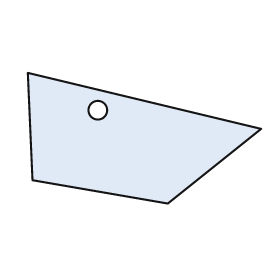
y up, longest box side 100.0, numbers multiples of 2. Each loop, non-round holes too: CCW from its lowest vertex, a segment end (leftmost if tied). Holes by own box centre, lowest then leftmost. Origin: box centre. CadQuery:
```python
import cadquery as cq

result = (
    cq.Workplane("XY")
    .moveTo(10.0, -28.0)
    .lineTo(50.0, 4.0)
    .lineTo(-50.0, 28.0)
    .lineTo(-48.0, -18.0)
    .close()
    .moveTo(-20.0, 12.0)
    .circle(4.0)
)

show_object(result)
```